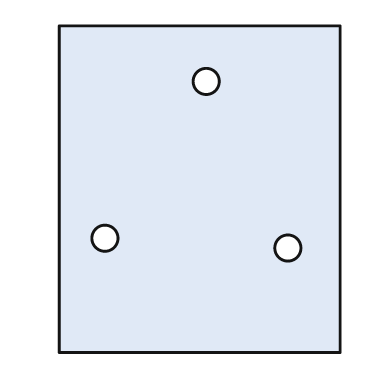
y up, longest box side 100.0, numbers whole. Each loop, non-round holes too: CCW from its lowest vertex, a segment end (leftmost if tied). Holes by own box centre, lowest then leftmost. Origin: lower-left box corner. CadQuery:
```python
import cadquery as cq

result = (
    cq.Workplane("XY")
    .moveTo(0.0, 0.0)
    .lineTo(86.0, 0.0)
    .lineTo(86.0, 100.0)
    .lineTo(0.0, 100.0)
    .close()
    .moveTo(70.0, 32.0)
    .circle(4.0)
    .moveTo(14.0, 35.0)
    .circle(4.0)
    .moveTo(45.0, 83.0)
    .circle(4.0)
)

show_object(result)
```